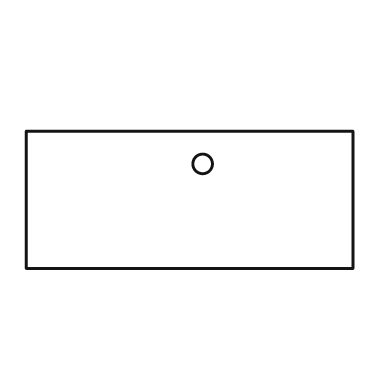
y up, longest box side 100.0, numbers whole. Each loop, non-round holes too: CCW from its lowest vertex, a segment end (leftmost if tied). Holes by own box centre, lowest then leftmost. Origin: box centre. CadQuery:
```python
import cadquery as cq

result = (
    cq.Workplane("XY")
    .moveTo(-50.0, -21.0)
    .lineTo(50.0, -21.0)
    .lineTo(50.0, 21.0)
    .lineTo(-50.0, 21.0)
    .close()
    .moveTo(4.0, 11.0)
    .circle(3.0)
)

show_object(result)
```